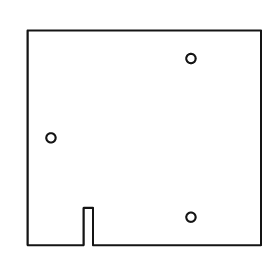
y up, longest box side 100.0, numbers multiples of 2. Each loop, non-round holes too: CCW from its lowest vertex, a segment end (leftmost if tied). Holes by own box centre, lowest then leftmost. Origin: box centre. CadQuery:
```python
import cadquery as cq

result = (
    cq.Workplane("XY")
    .moveTo(-50.0, -46.0)
    .lineTo(-26.0, -46.0)
    .lineTo(-26.0, -30.0)
    .lineTo(-22.0, -30.0)
    .lineTo(-22.0, -46.0)
    .lineTo(50.0, -46.0)
    .lineTo(50.0, 46.0)
    .lineTo(-50.0, 46.0)
    .close()
    .moveTo(20.0, -34.0)
    .circle(2.0)
    .moveTo(-40.0, 0.0)
    .circle(2.0)
    .moveTo(20.0, 34.0)
    .circle(2.0)
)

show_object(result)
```